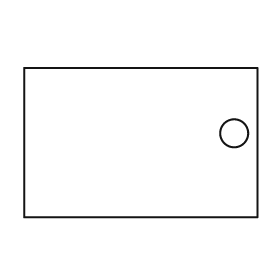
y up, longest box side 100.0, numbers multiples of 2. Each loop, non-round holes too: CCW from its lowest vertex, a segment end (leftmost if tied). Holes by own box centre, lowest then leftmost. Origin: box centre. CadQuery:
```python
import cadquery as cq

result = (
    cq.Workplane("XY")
    .moveTo(-50.0, -32.0)
    .lineTo(50.0, -32.0)
    .lineTo(50.0, 32.0)
    .lineTo(-50.0, 32.0)
    .close()
    .moveTo(40.0, 4.0)
    .circle(6.0)
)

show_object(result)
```